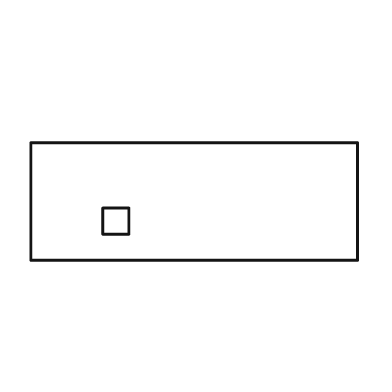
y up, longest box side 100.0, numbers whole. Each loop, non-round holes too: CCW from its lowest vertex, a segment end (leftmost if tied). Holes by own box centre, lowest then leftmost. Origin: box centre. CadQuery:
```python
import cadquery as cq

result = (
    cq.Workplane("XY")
    .moveTo(-50.0, -18.0)
    .lineTo(50.0, -18.0)
    .lineTo(50.0, 18.0)
    .lineTo(-50.0, 18.0)
    .close()
    .moveTo(-28.0, -10.0)
    .lineTo(-20.0, -10.0)
    .lineTo(-20.0, -2.0)
    .lineTo(-28.0, -2.0)
    .close()
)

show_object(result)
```